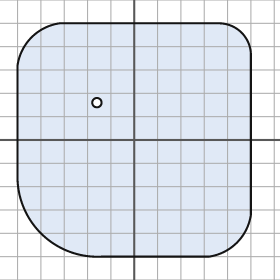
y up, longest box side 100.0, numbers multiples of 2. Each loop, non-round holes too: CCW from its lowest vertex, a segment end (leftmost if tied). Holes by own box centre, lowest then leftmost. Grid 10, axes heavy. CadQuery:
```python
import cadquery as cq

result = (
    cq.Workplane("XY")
    .moveTo(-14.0, -50.0)
    .lineTo(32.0, -50.0)
    .threePointArc((44.0, -44.0), (50.0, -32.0))
    .lineTo(50.0, 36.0)
    .threePointArc((46.0, 46.0), (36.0, 50.0))
    .lineTo(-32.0, 50.0)
    .threePointArc((-44.0, 44.0), (-50.0, 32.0))
    .lineTo(-50.0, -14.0)
    .threePointArc((-40.0, -40.0), (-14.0, -50.0))
    .close()
    .moveTo(-16.0, 16.0)
    .circle(2.0)
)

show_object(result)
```